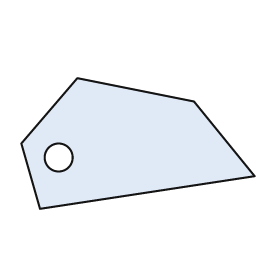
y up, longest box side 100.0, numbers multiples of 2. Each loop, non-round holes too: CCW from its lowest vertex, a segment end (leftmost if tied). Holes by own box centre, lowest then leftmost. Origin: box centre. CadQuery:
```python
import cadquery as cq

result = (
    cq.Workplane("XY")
    .moveTo(-42.0, -28.0)
    .lineTo(50.0, -14.0)
    .lineTo(24.0, 18.0)
    .lineTo(-26.0, 28.0)
    .lineTo(-50.0, 0.0)
    .close()
    .moveTo(-34.0, -6.0)
    .circle(6.0)
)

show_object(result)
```